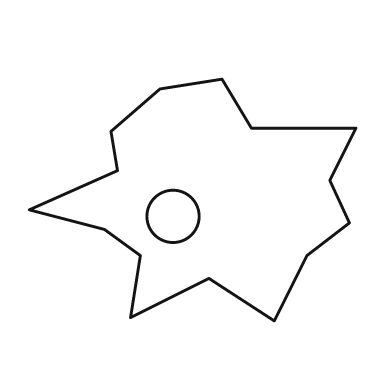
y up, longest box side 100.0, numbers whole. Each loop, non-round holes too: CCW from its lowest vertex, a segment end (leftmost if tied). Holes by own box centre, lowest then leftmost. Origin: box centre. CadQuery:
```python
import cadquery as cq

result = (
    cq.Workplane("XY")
    .moveTo(25.0, -37.0)
    .lineTo(35.0, -17.0)
    .lineTo(48.0, -7.0)
    .lineTo(42.0, 6.0)
    .lineTo(50.0, 22.0)
    .lineTo(18.0, 22.0)
    .lineTo(9.0, 37.0)
    .lineTo(-10.0, 34.0)
    .lineTo(-25.0, 21.0)
    .lineTo(-23.0, 9.0)
    .lineTo(-50.0, -3.0)
    .lineTo(-27.0, -9.0)
    .lineTo(-16.0, -17.0)
    .lineTo(-19.0, -36.0)
    .lineTo(5.0, -24.0)
    .close()
    .moveTo(-6.0, -5.0)
    .circle(8.0)
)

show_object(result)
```